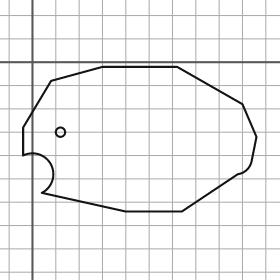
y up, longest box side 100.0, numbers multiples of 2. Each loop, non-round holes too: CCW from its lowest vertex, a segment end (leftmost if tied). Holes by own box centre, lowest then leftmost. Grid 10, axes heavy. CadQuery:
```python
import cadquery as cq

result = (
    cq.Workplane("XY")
    .moveTo(40.0, -64.0)
    .lineTo(64.0, -64.0)
    .lineTo(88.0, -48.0)
    .threePointArc((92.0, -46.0), (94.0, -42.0))
    .lineTo(96.0, -32.0)
    .lineTo(90.0, -18.0)
    .lineTo(62.0, -2.0)
    .lineTo(30.0, -2.0)
    .lineTo(8.0, -8.0)
    .lineTo(-4.0, -28.0)
    .lineTo(-4.0, -40.0)
    .threePointArc((8.0, -44.0), (4.0, -56.0))
    .close()
    .moveTo(12.0, -30.0)
    .circle(2.0)
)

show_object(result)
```